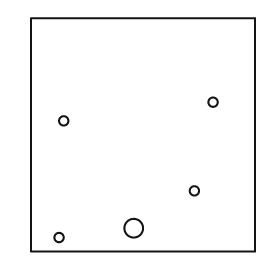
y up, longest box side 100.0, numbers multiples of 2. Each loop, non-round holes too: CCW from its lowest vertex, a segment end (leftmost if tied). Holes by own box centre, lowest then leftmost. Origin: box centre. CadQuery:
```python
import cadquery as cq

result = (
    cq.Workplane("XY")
    .moveTo(-48.0, -50.0)
    .lineTo(48.0, -50.0)
    .lineTo(48.0, 50.0)
    .lineTo(-48.0, 50.0)
    .close()
    .moveTo(-36.0, -44.0)
    .circle(2.0)
    .moveTo(-4.0, -40.0)
    .circle(4.0)
    .moveTo(22.0, -24.0)
    .circle(2.0)
    .moveTo(-34.0, 6.0)
    .circle(2.0)
    .moveTo(30.0, 14.0)
    .circle(2.0)
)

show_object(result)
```